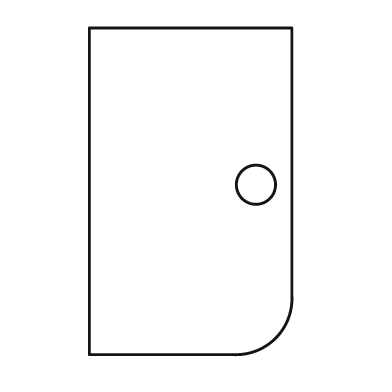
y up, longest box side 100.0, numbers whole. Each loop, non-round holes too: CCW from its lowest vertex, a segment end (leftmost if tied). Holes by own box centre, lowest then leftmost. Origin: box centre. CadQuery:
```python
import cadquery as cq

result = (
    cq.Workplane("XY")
    .moveTo(-31.0, -50.0)
    .lineTo(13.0, -50.0)
    .threePointArc((26.0, -45.0), (31.0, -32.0))
    .lineTo(31.0, 50.0)
    .lineTo(-31.0, 50.0)
    .close()
    .moveTo(20.0, 2.0)
    .circle(6.0)
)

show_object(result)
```